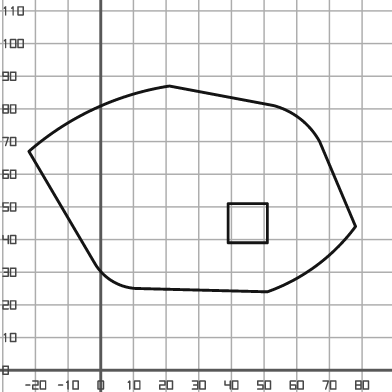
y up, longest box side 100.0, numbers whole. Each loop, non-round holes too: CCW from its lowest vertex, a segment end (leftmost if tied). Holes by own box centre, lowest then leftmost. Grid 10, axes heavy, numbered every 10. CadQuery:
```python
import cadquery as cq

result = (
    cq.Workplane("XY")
    .moveTo(51.0, 24.0)
    .threePointArc((66.0, 32.0), (78.0, 44.0))
    .lineTo(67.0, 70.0)
    .threePointArc((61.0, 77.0), (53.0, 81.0))
    .lineTo(21.0, 87.0)
    .threePointArc((-2.0, 80.0), (-22.0, 67.0))
    .lineTo(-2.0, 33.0)
    .threePointArc((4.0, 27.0), (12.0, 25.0))
    .close()
    .moveTo(39.0, 39.0)
    .lineTo(51.0, 39.0)
    .lineTo(51.0, 51.0)
    .lineTo(39.0, 51.0)
    .close()
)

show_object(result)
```